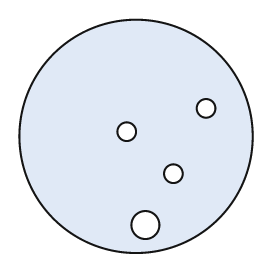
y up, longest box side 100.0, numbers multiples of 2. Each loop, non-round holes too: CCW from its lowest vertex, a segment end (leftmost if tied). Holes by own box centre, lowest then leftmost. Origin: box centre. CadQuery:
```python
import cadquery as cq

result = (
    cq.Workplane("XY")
    .moveTo(0.0, 0.0)
    .circle(50.0)
    .moveTo(4.0, -38.0)
    .circle(6.0)
    .moveTo(16.0, -16.0)
    .circle(4.0)
    .moveTo(-4.0, 2.0)
    .circle(4.0)
    .moveTo(30.0, 12.0)
    .circle(4.0)
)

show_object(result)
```